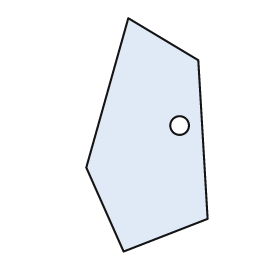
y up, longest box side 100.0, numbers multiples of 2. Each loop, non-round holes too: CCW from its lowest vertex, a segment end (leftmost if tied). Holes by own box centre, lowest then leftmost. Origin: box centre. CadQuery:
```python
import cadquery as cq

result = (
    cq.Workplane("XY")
    .moveTo(-10.0, -50.0)
    .lineTo(26.0, -36.0)
    .lineTo(22.0, 32.0)
    .lineTo(-8.0, 50.0)
    .lineTo(-26.0, -14.0)
    .close()
    .moveTo(14.0, 4.0)
    .circle(4.0)
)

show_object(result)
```